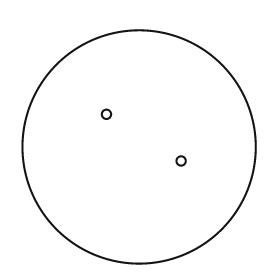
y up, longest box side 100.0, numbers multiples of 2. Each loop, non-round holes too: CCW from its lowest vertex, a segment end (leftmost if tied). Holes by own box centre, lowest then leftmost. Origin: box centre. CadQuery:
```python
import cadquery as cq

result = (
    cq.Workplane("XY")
    .moveTo(0.0, 0.0)
    .circle(50.0)
    .moveTo(18.0, -6.0)
    .circle(2.0)
    .moveTo(-14.0, 14.0)
    .circle(2.0)
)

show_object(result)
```